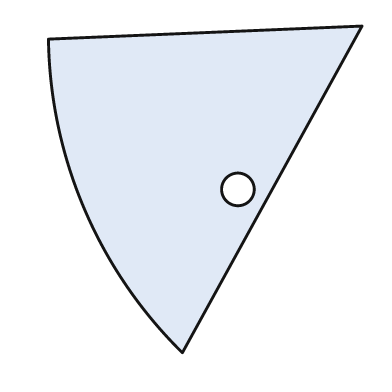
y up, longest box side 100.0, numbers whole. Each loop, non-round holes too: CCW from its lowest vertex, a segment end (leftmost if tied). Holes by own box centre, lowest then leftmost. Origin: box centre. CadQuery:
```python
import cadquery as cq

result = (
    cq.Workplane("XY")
    .moveTo(-7.0, -50.0)
    .lineTo(48.0, 50.0)
    .lineTo(-48.0, 46.0)
    .threePointArc((-37.0, -6.0), (-7.0, -50.0))
    .close()
    .moveTo(10.0, 0.0)
    .circle(5.0)
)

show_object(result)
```